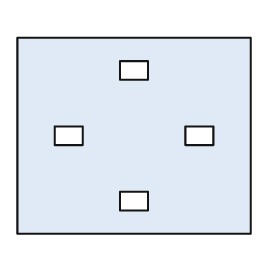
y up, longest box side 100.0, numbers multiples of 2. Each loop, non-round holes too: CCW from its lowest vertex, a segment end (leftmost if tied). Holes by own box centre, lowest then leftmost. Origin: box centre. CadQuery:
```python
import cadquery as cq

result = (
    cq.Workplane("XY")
    .moveTo(-50.0, -42.0)
    .lineTo(50.0, -42.0)
    .lineTo(50.0, 42.0)
    .lineTo(-50.0, 42.0)
    .close()
    .moveTo(-6.0, -32.0)
    .lineTo(6.0, -32.0)
    .lineTo(6.0, -24.0)
    .lineTo(-6.0, -24.0)
    .close()
    .moveTo(-34.0, -4.0)
    .lineTo(-22.0, -4.0)
    .lineTo(-22.0, 4.0)
    .lineTo(-34.0, 4.0)
    .close()
    .moveTo(22.0, -4.0)
    .lineTo(34.0, -4.0)
    .lineTo(34.0, 4.0)
    .lineTo(22.0, 4.0)
    .close()
    .moveTo(-6.0, 24.0)
    .lineTo(6.0, 24.0)
    .lineTo(6.0, 32.0)
    .lineTo(-6.0, 32.0)
    .close()
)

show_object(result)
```